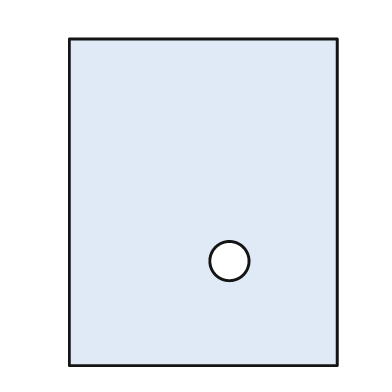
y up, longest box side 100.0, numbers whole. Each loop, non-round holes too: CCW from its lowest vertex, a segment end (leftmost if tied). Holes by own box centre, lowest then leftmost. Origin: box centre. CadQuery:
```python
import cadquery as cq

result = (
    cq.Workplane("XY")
    .moveTo(-41.0, -50.0)
    .lineTo(41.0, -50.0)
    .lineTo(41.0, 50.0)
    .lineTo(-41.0, 50.0)
    .close()
    .moveTo(8.0, -18.0)
    .circle(6.0)
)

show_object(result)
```